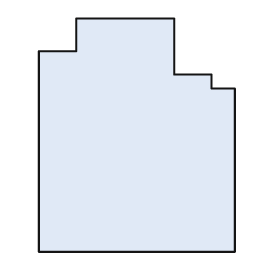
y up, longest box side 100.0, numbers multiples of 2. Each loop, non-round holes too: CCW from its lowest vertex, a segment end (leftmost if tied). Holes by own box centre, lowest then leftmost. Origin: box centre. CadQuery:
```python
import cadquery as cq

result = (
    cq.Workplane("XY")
    .moveTo(-42.0, -50.0)
    .lineTo(42.0, -50.0)
    .lineTo(42.0, 20.0)
    .lineTo(32.0, 20.0)
    .lineTo(32.0, 26.0)
    .lineTo(16.0, 26.0)
    .lineTo(16.0, 50.0)
    .lineTo(-26.0, 50.0)
    .lineTo(-26.0, 36.0)
    .lineTo(-42.0, 36.0)
    .close()
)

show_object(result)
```